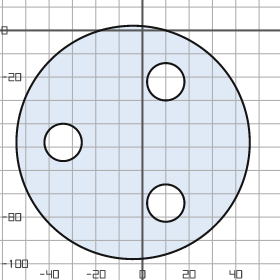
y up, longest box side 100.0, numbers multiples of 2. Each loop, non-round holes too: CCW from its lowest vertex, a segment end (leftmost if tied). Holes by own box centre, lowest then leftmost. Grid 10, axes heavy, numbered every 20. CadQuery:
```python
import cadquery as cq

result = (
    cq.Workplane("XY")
    .moveTo(-4.0, -48.0)
    .circle(50.0)
    .moveTo(10.0, -74.0)
    .circle(8.0)
    .moveTo(-34.0, -48.0)
    .circle(8.0)
    .moveTo(10.0, -22.0)
    .circle(8.0)
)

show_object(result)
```